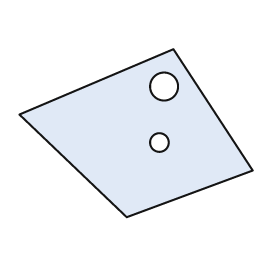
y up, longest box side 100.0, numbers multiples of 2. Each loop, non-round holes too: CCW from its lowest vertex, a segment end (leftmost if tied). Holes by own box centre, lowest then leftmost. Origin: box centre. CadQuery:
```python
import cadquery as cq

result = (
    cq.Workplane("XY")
    .moveTo(-4.0, -36.0)
    .lineTo(50.0, -16.0)
    .lineTo(16.0, 36.0)
    .lineTo(-50.0, 8.0)
    .close()
    .moveTo(10.0, -4.0)
    .circle(4.0)
    .moveTo(12.0, 20.0)
    .circle(6.0)
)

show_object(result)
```